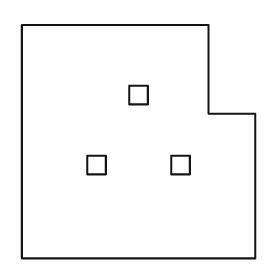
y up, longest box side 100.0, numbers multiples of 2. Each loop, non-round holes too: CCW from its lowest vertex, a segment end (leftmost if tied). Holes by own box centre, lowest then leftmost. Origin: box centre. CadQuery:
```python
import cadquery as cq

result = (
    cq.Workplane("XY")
    .moveTo(-50.0, -50.0)
    .lineTo(50.0, -50.0)
    .lineTo(50.0, 12.0)
    .lineTo(30.0, 12.0)
    .lineTo(30.0, 50.0)
    .lineTo(-50.0, 50.0)
    .close()
    .moveTo(-22.0, -14.0)
    .lineTo(-14.0, -14.0)
    .lineTo(-14.0, -6.0)
    .lineTo(-22.0, -6.0)
    .close()
    .moveTo(14.0, -14.0)
    .lineTo(22.0, -14.0)
    .lineTo(22.0, -6.0)
    .lineTo(14.0, -6.0)
    .close()
    .moveTo(-4.0, 16.0)
    .lineTo(4.0, 16.0)
    .lineTo(4.0, 24.0)
    .lineTo(-4.0, 24.0)
    .close()
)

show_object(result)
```